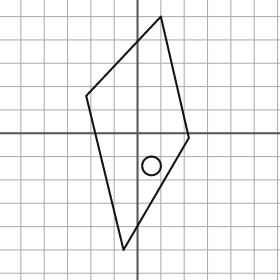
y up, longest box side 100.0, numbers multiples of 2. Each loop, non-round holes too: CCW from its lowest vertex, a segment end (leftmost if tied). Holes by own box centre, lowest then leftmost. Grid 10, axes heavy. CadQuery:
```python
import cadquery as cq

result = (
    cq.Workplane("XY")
    .moveTo(-6.0, -50.0)
    .lineTo(22.0, -2.0)
    .lineTo(10.0, 50.0)
    .lineTo(-22.0, 16.0)
    .close()
    .moveTo(6.0, -14.0)
    .circle(4.0)
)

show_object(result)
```